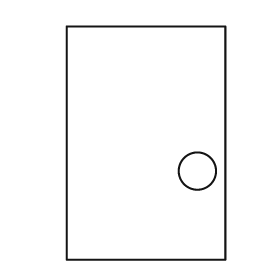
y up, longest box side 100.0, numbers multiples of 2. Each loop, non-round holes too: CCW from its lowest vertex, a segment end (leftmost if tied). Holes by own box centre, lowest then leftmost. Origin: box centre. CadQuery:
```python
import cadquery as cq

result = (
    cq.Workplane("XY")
    .moveTo(-34.0, -50.0)
    .lineTo(34.0, -50.0)
    .lineTo(34.0, 50.0)
    .lineTo(-34.0, 50.0)
    .close()
    .moveTo(22.0, -12.0)
    .circle(8.0)
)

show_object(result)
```